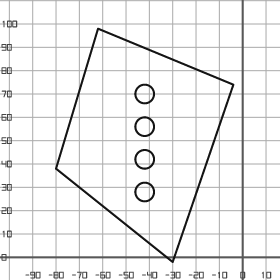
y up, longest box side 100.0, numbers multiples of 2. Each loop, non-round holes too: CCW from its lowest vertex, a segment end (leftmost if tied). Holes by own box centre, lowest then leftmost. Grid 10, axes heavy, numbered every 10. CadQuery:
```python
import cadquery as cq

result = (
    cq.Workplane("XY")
    .moveTo(-30.0, -2.0)
    .lineTo(-4.0, 74.0)
    .lineTo(-62.0, 98.0)
    .lineTo(-80.0, 38.0)
    .close()
    .moveTo(-42.0, 28.0)
    .circle(4.0)
    .moveTo(-42.0, 42.0)
    .circle(4.0)
    .moveTo(-42.0, 56.0)
    .circle(4.0)
    .moveTo(-42.0, 70.0)
    .circle(4.0)
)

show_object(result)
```